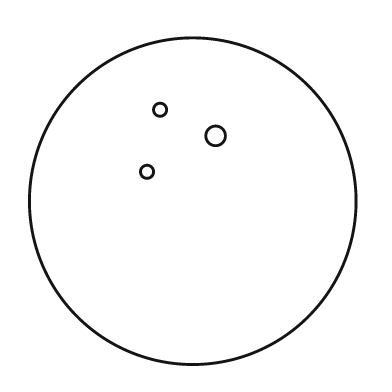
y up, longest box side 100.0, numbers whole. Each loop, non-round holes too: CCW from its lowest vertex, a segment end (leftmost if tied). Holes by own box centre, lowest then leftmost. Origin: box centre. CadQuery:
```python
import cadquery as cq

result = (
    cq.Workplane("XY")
    .moveTo(0.0, 0.0)
    .circle(50.0)
    .moveTo(-14.0, 9.0)
    .circle(2.0)
    .moveTo(7.0, 20.0)
    .circle(3.0)
    .moveTo(-10.0, 28.0)
    .circle(2.0)
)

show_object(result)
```